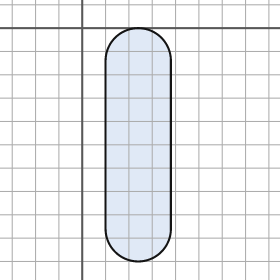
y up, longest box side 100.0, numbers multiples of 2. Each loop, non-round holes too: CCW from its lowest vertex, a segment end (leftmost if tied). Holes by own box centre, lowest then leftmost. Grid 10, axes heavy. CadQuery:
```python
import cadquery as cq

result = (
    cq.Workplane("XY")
    .moveTo(10.0, -86.0)
    .threePointArc((24.0, -100.0), (38.0, -86.0))
    .lineTo(38.0, -14.0)
    .threePointArc((24.0, 0.0), (10.0, -14.0))
    .close()
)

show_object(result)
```